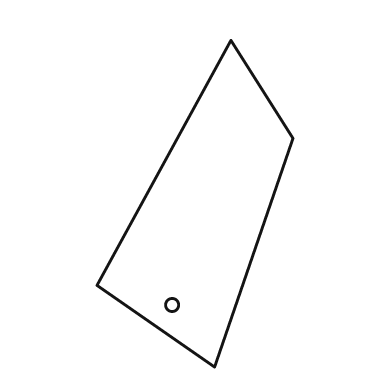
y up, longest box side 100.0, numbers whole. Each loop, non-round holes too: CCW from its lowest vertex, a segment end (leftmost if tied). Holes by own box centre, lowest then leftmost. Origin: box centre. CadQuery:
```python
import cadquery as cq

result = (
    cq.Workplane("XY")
    .moveTo(6.0, -50.0)
    .lineTo(30.0, 20.0)
    .lineTo(11.0, 50.0)
    .lineTo(-30.0, -25.0)
    .close()
    .moveTo(-7.0, -31.0)
    .circle(2.0)
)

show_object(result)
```